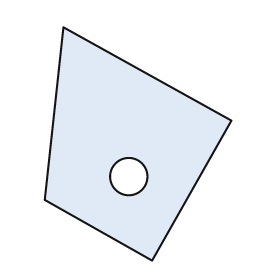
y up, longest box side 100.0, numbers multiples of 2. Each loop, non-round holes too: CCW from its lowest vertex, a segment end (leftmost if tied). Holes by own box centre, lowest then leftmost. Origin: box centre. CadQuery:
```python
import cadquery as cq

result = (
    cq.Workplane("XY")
    .moveTo(6.0, -50.0)
    .lineTo(40.0, 10.0)
    .lineTo(-32.0, 50.0)
    .lineTo(-40.0, -24.0)
    .close()
    .moveTo(-4.0, -14.0)
    .circle(8.0)
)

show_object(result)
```